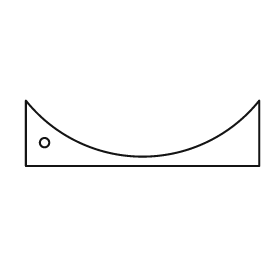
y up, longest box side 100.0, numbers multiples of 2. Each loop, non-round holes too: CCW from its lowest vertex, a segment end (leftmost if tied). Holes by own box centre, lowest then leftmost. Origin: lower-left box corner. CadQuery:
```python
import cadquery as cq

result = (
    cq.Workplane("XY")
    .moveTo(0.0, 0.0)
    .lineTo(100.0, 0.0)
    .lineTo(100.0, 28.0)
    .threePointArc((50.0, 4.0), (0.0, 28.0))
    .close()
    .moveTo(8.0, 10.0)
    .circle(2.0)
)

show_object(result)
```